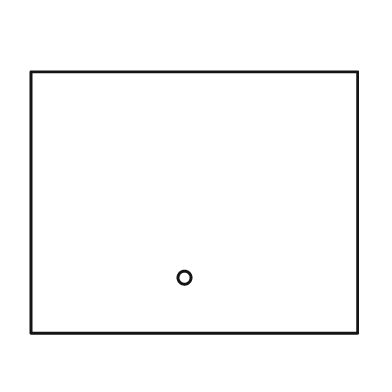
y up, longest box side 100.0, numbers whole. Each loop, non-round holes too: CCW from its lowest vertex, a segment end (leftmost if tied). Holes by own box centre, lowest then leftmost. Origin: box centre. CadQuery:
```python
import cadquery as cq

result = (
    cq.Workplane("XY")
    .moveTo(-50.0, -40.0)
    .lineTo(50.0, -40.0)
    .lineTo(50.0, 40.0)
    .lineTo(-50.0, 40.0)
    .close()
    .moveTo(-3.0, -23.0)
    .circle(2.0)
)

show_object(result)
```